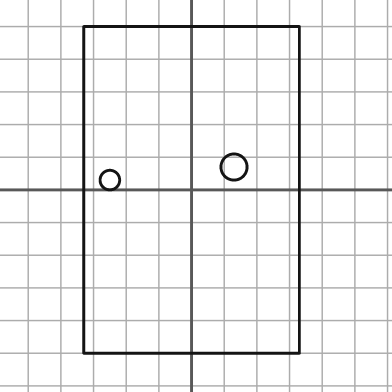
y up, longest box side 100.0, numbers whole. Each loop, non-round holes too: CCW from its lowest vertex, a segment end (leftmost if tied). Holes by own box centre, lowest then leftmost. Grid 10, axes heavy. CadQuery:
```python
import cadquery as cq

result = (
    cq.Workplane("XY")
    .moveTo(-33.0, -50.0)
    .lineTo(33.0, -50.0)
    .lineTo(33.0, 50.0)
    .lineTo(-33.0, 50.0)
    .close()
    .moveTo(-25.0, 3.0)
    .circle(3.0)
    .moveTo(13.0, 7.0)
    .circle(4.0)
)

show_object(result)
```